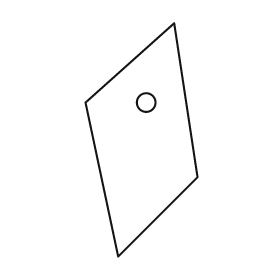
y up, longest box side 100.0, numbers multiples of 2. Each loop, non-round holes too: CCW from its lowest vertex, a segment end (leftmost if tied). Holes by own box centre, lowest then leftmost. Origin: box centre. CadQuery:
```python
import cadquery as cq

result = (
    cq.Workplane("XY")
    .moveTo(-10.0, -50.0)
    .lineTo(24.0, -16.0)
    .lineTo(14.0, 50.0)
    .lineTo(-24.0, 16.0)
    .close()
    .moveTo(2.0, 16.0)
    .circle(4.0)
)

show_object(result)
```